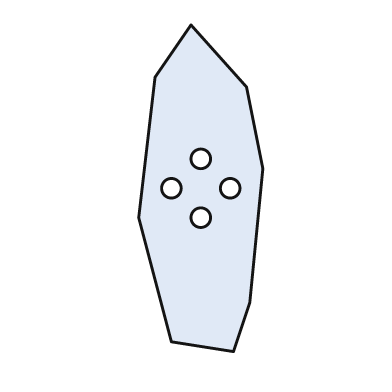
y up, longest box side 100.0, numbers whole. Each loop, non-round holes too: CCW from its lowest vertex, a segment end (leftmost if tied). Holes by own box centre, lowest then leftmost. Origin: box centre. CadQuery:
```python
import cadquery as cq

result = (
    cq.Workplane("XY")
    .moveTo(10.0, -50.0)
    .lineTo(15.0, -35.0)
    .lineTo(19.0, 6.0)
    .lineTo(14.0, 31.0)
    .lineTo(-3.0, 50.0)
    .lineTo(-14.0, 34.0)
    .lineTo(-19.0, -9.0)
    .lineTo(-9.0, -47.0)
    .close()
    .moveTo(0.0, -9.0)
    .circle(3.0)
    .moveTo(-9.0, 0.0)
    .circle(3.0)
    .moveTo(9.0, 0.0)
    .circle(3.0)
    .moveTo(0.0, 9.0)
    .circle(3.0)
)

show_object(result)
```